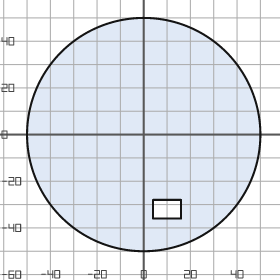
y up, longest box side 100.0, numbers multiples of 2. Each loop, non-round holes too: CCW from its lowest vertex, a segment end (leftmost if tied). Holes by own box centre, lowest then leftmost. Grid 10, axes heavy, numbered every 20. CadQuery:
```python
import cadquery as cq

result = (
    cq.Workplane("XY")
    .moveTo(0.0, 0.0)
    .circle(50.0)
    .moveTo(4.0, -36.0)
    .lineTo(16.0, -36.0)
    .lineTo(16.0, -28.0)
    .lineTo(4.0, -28.0)
    .close()
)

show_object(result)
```